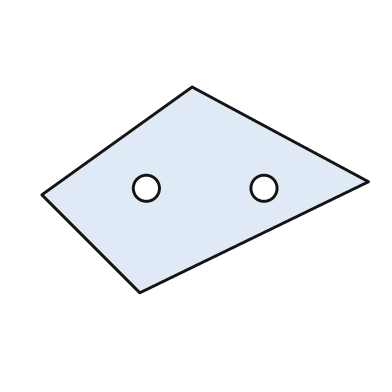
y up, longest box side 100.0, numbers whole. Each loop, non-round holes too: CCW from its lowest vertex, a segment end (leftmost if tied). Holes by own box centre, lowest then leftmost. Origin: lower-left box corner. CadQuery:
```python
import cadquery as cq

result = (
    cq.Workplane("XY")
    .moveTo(30.0, 0.0)
    .lineTo(100.0, 34.0)
    .lineTo(46.0, 63.0)
    .lineTo(0.0, 30.0)
    .close()
    .moveTo(32.0, 32.0)
    .circle(4.0)
    .moveTo(68.0, 32.0)
    .circle(4.0)
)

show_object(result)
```